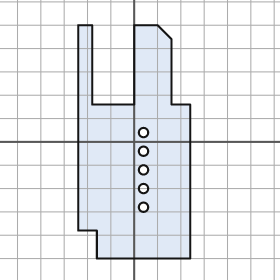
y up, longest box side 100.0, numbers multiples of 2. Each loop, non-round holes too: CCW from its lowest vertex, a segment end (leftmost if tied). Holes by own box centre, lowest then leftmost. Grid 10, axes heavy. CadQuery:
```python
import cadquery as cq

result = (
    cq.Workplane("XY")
    .moveTo(-16.0, -50.0)
    .lineTo(24.0, -50.0)
    .lineTo(24.0, 16.0)
    .lineTo(16.0, 16.0)
    .lineTo(16.0, 44.0)
    .lineTo(10.0, 50.0)
    .lineTo(0.0, 50.0)
    .lineTo(0.0, 16.0)
    .lineTo(-18.0, 16.0)
    .lineTo(-18.0, 50.0)
    .lineTo(-24.0, 50.0)
    .lineTo(-24.0, -38.0)
    .lineTo(-16.0, -38.0)
    .close()
    .moveTo(4.0, -28.0)
    .circle(2.0)
    .moveTo(4.0, -20.0)
    .circle(2.0)
    .moveTo(4.0, -12.0)
    .circle(2.0)
    .moveTo(4.0, -4.0)
    .circle(2.0)
    .moveTo(4.0, 4.0)
    .circle(2.0)
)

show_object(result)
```